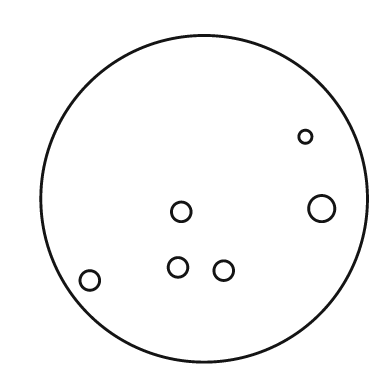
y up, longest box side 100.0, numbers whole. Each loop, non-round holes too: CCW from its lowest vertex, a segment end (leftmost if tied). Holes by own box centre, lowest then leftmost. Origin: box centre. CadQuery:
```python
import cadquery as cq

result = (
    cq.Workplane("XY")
    .moveTo(0.0, 0.0)
    .circle(50.0)
    .moveTo(-35.0, -25.0)
    .circle(3.0)
    .moveTo(6.0, -22.0)
    .circle(3.0)
    .moveTo(-8.0, -21.0)
    .circle(3.0)
    .moveTo(-7.0, -4.0)
    .circle(3.0)
    .moveTo(36.0, -3.0)
    .circle(4.0)
    .moveTo(31.0, 19.0)
    .circle(2.0)
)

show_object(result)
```